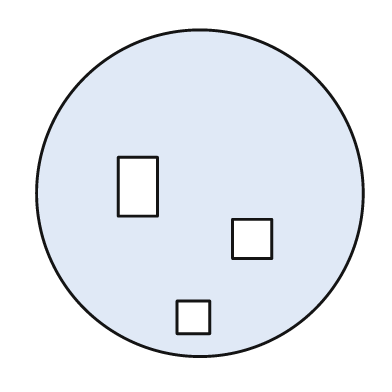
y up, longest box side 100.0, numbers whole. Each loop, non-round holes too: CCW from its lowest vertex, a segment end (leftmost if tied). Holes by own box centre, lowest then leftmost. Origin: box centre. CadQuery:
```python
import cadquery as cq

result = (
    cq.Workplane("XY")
    .moveTo(0.0, 0.0)
    .circle(50.0)
    .moveTo(-7.0, -43.0)
    .lineTo(3.0, -43.0)
    .lineTo(3.0, -33.0)
    .lineTo(-7.0, -33.0)
    .close()
    .moveTo(10.0, -20.0)
    .lineTo(22.0, -20.0)
    .lineTo(22.0, -8.0)
    .lineTo(10.0, -8.0)
    .close()
    .moveTo(-25.0, -7.0)
    .lineTo(-13.0, -7.0)
    .lineTo(-13.0, 11.0)
    .lineTo(-25.0, 11.0)
    .close()
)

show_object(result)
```